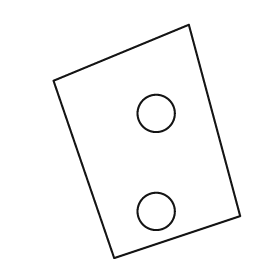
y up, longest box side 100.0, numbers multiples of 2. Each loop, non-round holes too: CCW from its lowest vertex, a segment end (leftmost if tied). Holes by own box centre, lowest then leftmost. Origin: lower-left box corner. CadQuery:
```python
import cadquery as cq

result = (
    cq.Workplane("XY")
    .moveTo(26.0, 0.0)
    .lineTo(80.0, 18.0)
    .lineTo(58.0, 100.0)
    .lineTo(0.0, 76.0)
    .close()
    .moveTo(44.0, 20.0)
    .circle(8.0)
    .moveTo(44.0, 62.0)
    .circle(8.0)
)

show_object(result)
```